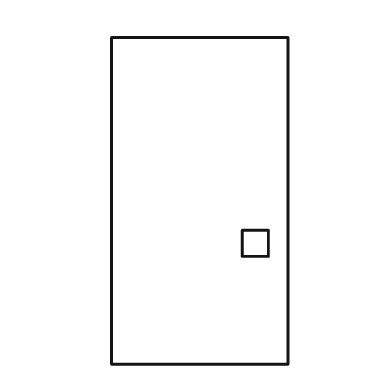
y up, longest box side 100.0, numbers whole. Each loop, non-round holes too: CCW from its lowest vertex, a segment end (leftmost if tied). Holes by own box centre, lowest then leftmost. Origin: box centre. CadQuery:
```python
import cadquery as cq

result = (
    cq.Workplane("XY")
    .moveTo(-27.0, -50.0)
    .lineTo(27.0, -50.0)
    .lineTo(27.0, 50.0)
    .lineTo(-27.0, 50.0)
    .close()
    .moveTo(13.0, -17.0)
    .lineTo(21.0, -17.0)
    .lineTo(21.0, -9.0)
    .lineTo(13.0, -9.0)
    .close()
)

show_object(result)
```